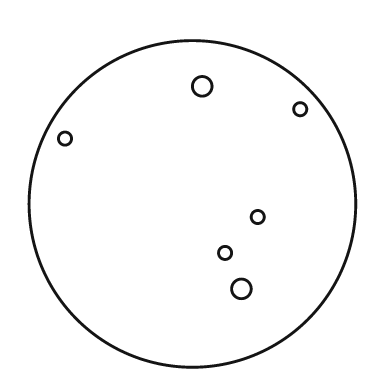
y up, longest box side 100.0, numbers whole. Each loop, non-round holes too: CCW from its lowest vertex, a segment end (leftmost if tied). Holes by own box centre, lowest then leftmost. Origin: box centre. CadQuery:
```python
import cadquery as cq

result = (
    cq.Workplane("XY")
    .moveTo(0.0, 0.0)
    .circle(50.0)
    .moveTo(15.0, -26.0)
    .circle(3.0)
    .moveTo(10.0, -15.0)
    .circle(2.0)
    .moveTo(20.0, -4.0)
    .circle(2.0)
    .moveTo(-39.0, 20.0)
    .circle(2.0)
    .moveTo(33.0, 29.0)
    .circle(2.0)
    .moveTo(3.0, 36.0)
    .circle(3.0)
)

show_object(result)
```